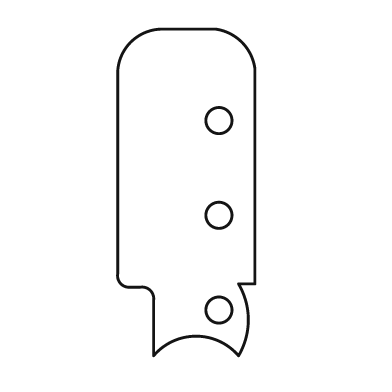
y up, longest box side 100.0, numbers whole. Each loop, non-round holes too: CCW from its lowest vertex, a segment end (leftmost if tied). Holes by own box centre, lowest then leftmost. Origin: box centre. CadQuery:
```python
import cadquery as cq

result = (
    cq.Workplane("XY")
    .moveTo(-10.0, -50.0)
    .threePointArc((3.0, -44.0), (16.0, -50.0))
    .threePointArc((19.0, -39.0), (16.0, -28.0))
    .lineTo(21.0, -28.0)
    .lineTo(21.0, 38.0)
    .threePointArc((17.0, 46.0), (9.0, 50.0))
    .lineTo(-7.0, 50.0)
    .threePointArc((-17.0, 46.0), (-21.0, 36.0))
    .lineTo(-21.0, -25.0)
    .threePointArc((-20.0, -28.0), (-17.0, -29.0))
    .lineTo(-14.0, -29.0)
    .threePointArc((-11.0, -30.0), (-10.0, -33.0))
    .close()
    .moveTo(10.0, -36.0)
    .circle(4.0)
    .moveTo(10.0, -7.0)
    .circle(4.0)
    .moveTo(10.0, 22.0)
    .circle(4.0)
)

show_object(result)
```